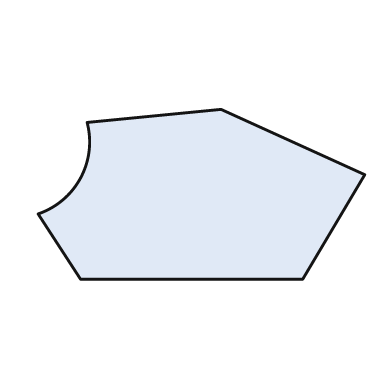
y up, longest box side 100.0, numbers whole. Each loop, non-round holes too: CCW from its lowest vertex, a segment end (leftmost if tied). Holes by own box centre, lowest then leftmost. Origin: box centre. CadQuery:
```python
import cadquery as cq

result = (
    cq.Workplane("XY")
    .moveTo(-37.0, -26.0)
    .lineTo(31.0, -26.0)
    .lineTo(50.0, 6.0)
    .lineTo(6.0, 26.0)
    .lineTo(-35.0, 22.0)
    .threePointArc((-37.0, 5.0), (-50.0, -6.0))
    .close()
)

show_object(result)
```